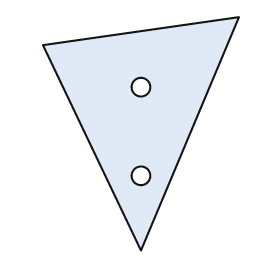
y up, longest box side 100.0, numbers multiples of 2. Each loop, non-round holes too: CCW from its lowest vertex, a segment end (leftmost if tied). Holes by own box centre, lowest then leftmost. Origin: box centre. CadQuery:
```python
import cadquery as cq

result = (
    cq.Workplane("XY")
    .moveTo(0.0, -50.0)
    .lineTo(42.0, 50.0)
    .lineTo(-42.0, 38.0)
    .close()
    .moveTo(0.0, -18.0)
    .circle(4.0)
    .moveTo(0.0, 20.0)
    .circle(4.0)
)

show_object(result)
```